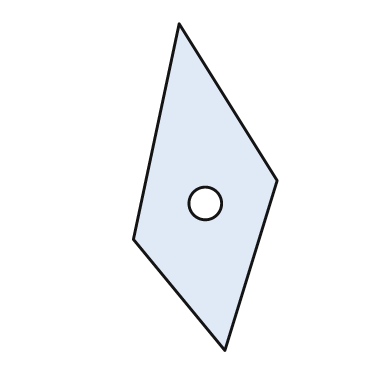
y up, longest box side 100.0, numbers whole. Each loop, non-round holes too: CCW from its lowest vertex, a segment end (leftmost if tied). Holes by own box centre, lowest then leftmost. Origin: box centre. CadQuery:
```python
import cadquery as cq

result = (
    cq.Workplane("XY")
    .moveTo(6.0, -50.0)
    .lineTo(22.0, 2.0)
    .lineTo(-8.0, 50.0)
    .lineTo(-22.0, -16.0)
    .close()
    .moveTo(0.0, -5.0)
    .circle(5.0)
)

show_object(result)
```